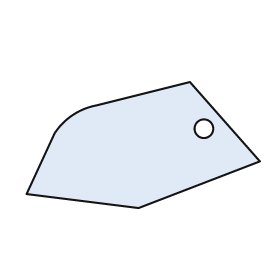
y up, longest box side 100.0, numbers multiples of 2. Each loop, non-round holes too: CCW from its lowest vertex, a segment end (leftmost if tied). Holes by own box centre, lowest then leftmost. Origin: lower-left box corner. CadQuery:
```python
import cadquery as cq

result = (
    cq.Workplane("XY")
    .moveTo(48.0, 0.0)
    .lineTo(100.0, 20.0)
    .lineTo(70.0, 54.0)
    .lineTo(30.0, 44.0)
    .threePointArc((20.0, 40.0), (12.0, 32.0))
    .lineTo(0.0, 6.0)
    .close()
    .moveTo(76.0, 34.0)
    .circle(4.0)
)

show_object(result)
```